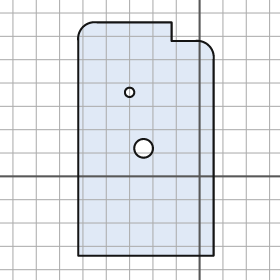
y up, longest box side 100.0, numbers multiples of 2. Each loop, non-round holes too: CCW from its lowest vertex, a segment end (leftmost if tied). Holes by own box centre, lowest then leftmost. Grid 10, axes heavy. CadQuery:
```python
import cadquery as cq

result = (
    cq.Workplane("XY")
    .moveTo(-52.0, -34.0)
    .lineTo(6.0, -34.0)
    .lineTo(6.0, 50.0)
    .threePointArc((4.0, 56.0), (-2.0, 58.0))
    .lineTo(-12.0, 58.0)
    .lineTo(-12.0, 66.0)
    .lineTo(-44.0, 66.0)
    .threePointArc((-50.0, 64.0), (-52.0, 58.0))
    .close()
    .moveTo(-24.0, 12.0)
    .circle(4.0)
    .moveTo(-30.0, 36.0)
    .circle(2.0)
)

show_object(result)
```